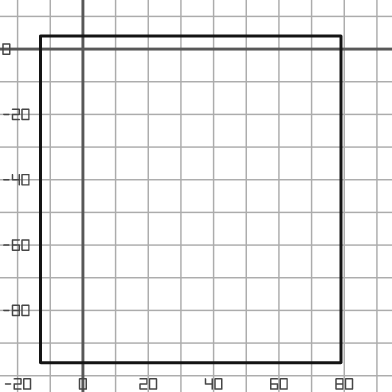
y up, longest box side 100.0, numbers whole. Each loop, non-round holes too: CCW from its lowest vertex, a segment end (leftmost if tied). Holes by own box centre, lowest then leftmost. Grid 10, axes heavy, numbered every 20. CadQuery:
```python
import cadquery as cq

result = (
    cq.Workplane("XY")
    .moveTo(-13.0, -96.0)
    .lineTo(79.0, -96.0)
    .lineTo(79.0, 4.0)
    .lineTo(-13.0, 4.0)
    .close()
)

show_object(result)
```